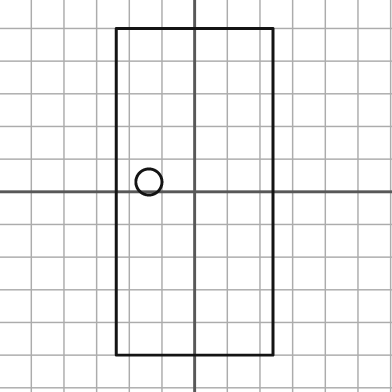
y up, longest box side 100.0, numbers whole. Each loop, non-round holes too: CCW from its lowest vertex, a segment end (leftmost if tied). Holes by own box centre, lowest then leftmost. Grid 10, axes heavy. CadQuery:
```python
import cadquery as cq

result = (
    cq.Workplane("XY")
    .moveTo(-24.0, -50.0)
    .lineTo(24.0, -50.0)
    .lineTo(24.0, 50.0)
    .lineTo(-24.0, 50.0)
    .close()
    .moveTo(-14.0, 3.0)
    .circle(4.0)
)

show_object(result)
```